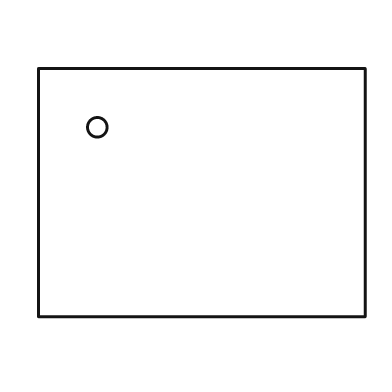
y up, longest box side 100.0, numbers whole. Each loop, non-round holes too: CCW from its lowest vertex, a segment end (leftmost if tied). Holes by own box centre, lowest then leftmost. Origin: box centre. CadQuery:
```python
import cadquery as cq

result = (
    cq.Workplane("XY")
    .moveTo(-50.0, -38.0)
    .lineTo(50.0, -38.0)
    .lineTo(50.0, 38.0)
    .lineTo(-50.0, 38.0)
    .close()
    .moveTo(-32.0, 20.0)
    .circle(3.0)
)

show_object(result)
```